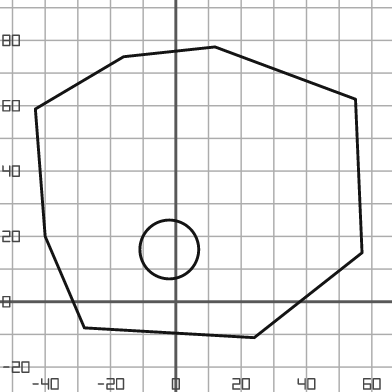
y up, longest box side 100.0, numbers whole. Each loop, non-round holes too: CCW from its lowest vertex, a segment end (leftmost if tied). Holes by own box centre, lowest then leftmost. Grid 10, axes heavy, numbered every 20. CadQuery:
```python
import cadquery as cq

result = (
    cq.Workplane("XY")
    .moveTo(24.0, -11.0)
    .lineTo(57.0, 15.0)
    .lineTo(55.0, 62.0)
    .lineTo(12.0, 78.0)
    .lineTo(-16.0, 75.0)
    .lineTo(-43.0, 59.0)
    .lineTo(-40.0, 20.0)
    .lineTo(-28.0, -8.0)
    .close()
    .moveTo(-2.0, 16.0)
    .circle(9.0)
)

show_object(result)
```